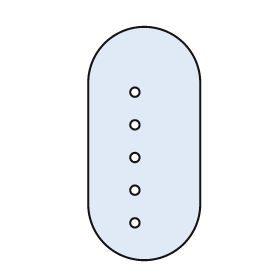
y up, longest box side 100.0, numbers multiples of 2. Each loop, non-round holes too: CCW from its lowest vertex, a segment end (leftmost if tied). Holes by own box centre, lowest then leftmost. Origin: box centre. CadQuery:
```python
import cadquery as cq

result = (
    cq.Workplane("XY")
    .moveTo(-24.0, -26.0)
    .threePointArc((0.0, -50.0), (24.0, -26.0))
    .lineTo(24.0, 26.0)
    .threePointArc((0.0, 50.0), (-24.0, 26.0))
    .close()
    .moveTo(-4.0, -34.0)
    .circle(2.0)
    .moveTo(-4.0, -20.0)
    .circle(2.0)
    .moveTo(-4.0, -6.0)
    .circle(2.0)
    .moveTo(-4.0, 8.0)
    .circle(2.0)
    .moveTo(-4.0, 22.0)
    .circle(2.0)
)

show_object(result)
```